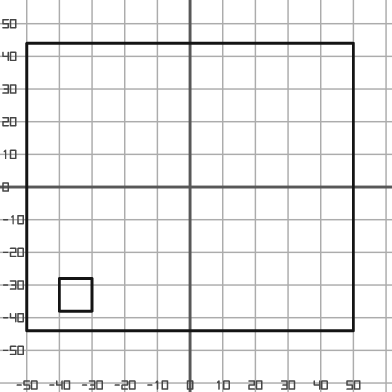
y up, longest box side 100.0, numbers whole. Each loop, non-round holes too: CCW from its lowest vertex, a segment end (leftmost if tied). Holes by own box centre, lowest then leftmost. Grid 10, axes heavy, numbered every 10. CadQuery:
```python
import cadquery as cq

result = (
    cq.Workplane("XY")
    .moveTo(-50.0, -44.0)
    .lineTo(50.0, -44.0)
    .lineTo(50.0, 44.0)
    .lineTo(-50.0, 44.0)
    .close()
    .moveTo(-40.0, -38.0)
    .lineTo(-30.0, -38.0)
    .lineTo(-30.0, -28.0)
    .lineTo(-40.0, -28.0)
    .close()
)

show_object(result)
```